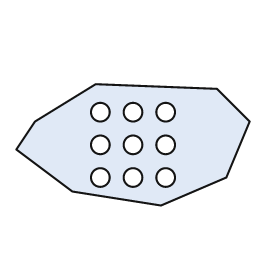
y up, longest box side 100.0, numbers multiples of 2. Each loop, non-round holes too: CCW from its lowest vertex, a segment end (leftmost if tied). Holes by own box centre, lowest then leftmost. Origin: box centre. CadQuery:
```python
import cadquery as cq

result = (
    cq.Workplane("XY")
    .moveTo(12.0, -26.0)
    .lineTo(40.0, -14.0)
    .lineTo(50.0, 10.0)
    .lineTo(36.0, 24.0)
    .lineTo(-16.0, 26.0)
    .lineTo(-42.0, 10.0)
    .lineTo(-50.0, -2.0)
    .lineTo(-26.0, -20.0)
    .close()
    .moveTo(-14.0, -14.0)
    .circle(4.0)
    .moveTo(0.0, -14.0)
    .circle(4.0)
    .moveTo(14.0, -14.0)
    .circle(4.0)
    .moveTo(-14.0, 0.0)
    .circle(4.0)
    .moveTo(0.0, 0.0)
    .circle(4.0)
    .moveTo(14.0, 0.0)
    .circle(4.0)
    .moveTo(-14.0, 14.0)
    .circle(4.0)
    .moveTo(0.0, 14.0)
    .circle(4.0)
    .moveTo(14.0, 14.0)
    .circle(4.0)
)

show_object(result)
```